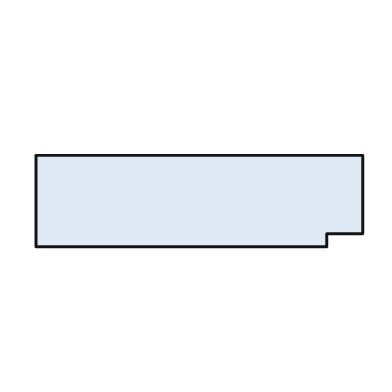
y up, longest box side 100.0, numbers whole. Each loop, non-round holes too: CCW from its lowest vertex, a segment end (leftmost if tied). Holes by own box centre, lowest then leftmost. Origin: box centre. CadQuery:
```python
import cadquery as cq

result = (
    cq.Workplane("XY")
    .moveTo(-50.0, -14.0)
    .lineTo(39.0, -14.0)
    .lineTo(39.0, -10.0)
    .lineTo(50.0, -10.0)
    .lineTo(50.0, 14.0)
    .lineTo(-50.0, 14.0)
    .close()
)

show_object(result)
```